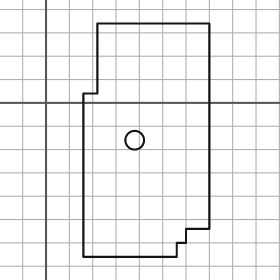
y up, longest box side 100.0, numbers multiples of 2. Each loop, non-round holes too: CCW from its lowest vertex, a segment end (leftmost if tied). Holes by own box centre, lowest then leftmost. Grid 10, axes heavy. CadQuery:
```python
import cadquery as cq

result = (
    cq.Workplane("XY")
    .moveTo(16.0, -66.0)
    .lineTo(56.0, -66.0)
    .lineTo(56.0, -60.0)
    .lineTo(60.0, -60.0)
    .lineTo(60.0, -54.0)
    .lineTo(70.0, -54.0)
    .lineTo(70.0, 34.0)
    .lineTo(22.0, 34.0)
    .lineTo(22.0, 4.0)
    .lineTo(16.0, 4.0)
    .close()
    .moveTo(38.0, -16.0)
    .circle(4.0)
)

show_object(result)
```